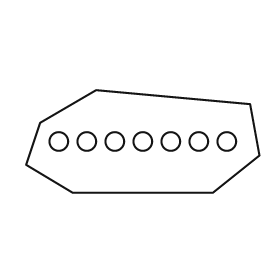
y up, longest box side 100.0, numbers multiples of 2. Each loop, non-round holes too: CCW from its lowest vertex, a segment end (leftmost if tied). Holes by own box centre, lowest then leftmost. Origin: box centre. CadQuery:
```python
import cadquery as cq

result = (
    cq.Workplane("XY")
    .moveTo(-30.0, -22.0)
    .lineTo(30.0, -22.0)
    .lineTo(50.0, -6.0)
    .lineTo(46.0, 16.0)
    .lineTo(-20.0, 22.0)
    .lineTo(-44.0, 8.0)
    .lineTo(-50.0, -10.0)
    .close()
    .moveTo(-36.0, 0.0)
    .circle(4.0)
    .moveTo(-24.0, 0.0)
    .circle(4.0)
    .moveTo(-12.0, 0.0)
    .circle(4.0)
    .moveTo(0.0, 0.0)
    .circle(4.0)
    .moveTo(12.0, 0.0)
    .circle(4.0)
    .moveTo(24.0, 0.0)
    .circle(4.0)
    .moveTo(36.0, 0.0)
    .circle(4.0)
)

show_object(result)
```